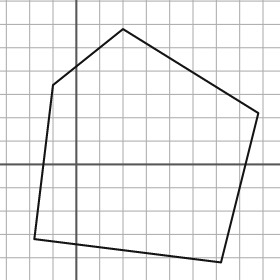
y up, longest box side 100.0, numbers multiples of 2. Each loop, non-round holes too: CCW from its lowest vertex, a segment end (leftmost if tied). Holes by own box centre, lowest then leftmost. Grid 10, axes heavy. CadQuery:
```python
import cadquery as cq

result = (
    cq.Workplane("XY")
    .moveTo(62.0, -42.0)
    .lineTo(78.0, 22.0)
    .lineTo(20.0, 58.0)
    .lineTo(-10.0, 34.0)
    .lineTo(-18.0, -32.0)
    .close()
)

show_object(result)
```